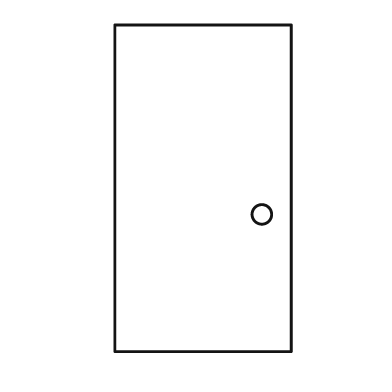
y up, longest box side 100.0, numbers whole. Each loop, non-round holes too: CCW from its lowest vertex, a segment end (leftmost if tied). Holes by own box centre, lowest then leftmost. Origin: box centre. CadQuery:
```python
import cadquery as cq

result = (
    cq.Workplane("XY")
    .moveTo(-27.0, -50.0)
    .lineTo(27.0, -50.0)
    .lineTo(27.0, 50.0)
    .lineTo(-27.0, 50.0)
    .close()
    .moveTo(18.0, -8.0)
    .circle(3.0)
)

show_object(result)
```